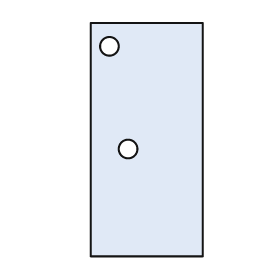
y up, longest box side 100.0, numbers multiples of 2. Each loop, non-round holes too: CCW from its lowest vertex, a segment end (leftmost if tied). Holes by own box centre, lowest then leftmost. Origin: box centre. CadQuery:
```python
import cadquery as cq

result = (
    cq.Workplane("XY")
    .moveTo(-24.0, -50.0)
    .lineTo(24.0, -50.0)
    .lineTo(24.0, 50.0)
    .lineTo(-24.0, 50.0)
    .close()
    .moveTo(-8.0, -4.0)
    .circle(4.0)
    .moveTo(-16.0, 40.0)
    .circle(4.0)
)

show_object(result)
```